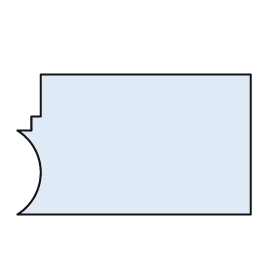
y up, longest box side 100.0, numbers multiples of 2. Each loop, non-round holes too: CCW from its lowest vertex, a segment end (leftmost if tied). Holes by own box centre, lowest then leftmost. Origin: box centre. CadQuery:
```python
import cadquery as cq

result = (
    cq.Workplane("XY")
    .moveTo(-50.0, -30.0)
    .lineTo(50.0, -30.0)
    .lineTo(50.0, 30.0)
    .lineTo(-40.0, 30.0)
    .lineTo(-40.0, 12.0)
    .lineTo(-44.0, 12.0)
    .lineTo(-44.0, 6.0)
    .lineTo(-50.0, 6.0)
    .threePointArc((-40.0, -12.0), (-50.0, -30.0))
    .close()
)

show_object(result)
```